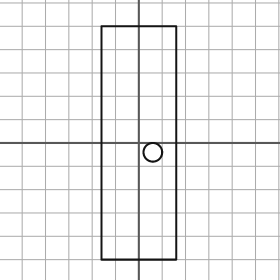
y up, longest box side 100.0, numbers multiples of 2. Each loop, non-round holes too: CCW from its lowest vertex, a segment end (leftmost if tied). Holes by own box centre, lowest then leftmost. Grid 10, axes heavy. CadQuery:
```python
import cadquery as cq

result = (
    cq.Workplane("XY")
    .moveTo(-16.0, -50.0)
    .lineTo(16.0, -50.0)
    .lineTo(16.0, 50.0)
    .lineTo(-16.0, 50.0)
    .close()
    .moveTo(6.0, -4.0)
    .circle(4.0)
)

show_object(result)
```